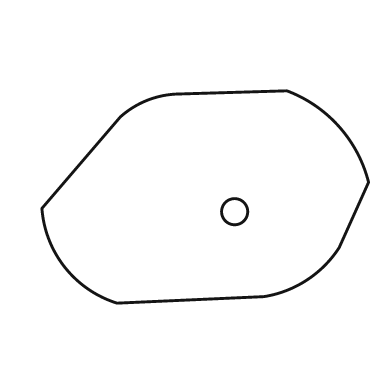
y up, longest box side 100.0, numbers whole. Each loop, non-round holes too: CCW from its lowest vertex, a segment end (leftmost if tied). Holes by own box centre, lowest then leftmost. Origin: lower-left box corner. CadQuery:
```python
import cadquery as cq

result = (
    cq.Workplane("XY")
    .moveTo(23.0, 0.0)
    .lineTo(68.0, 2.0)
    .threePointArc((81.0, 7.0), (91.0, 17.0))
    .lineTo(100.0, 37.0)
    .threePointArc((91.0, 54.0), (75.0, 65.0))
    .lineTo(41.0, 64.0)
    .threePointArc((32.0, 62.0), (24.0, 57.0))
    .lineTo(0.0, 29.0)
    .threePointArc((7.0, 11.0), (23.0, 0.0))
    .close()
    .moveTo(59.0, 28.0)
    .circle(4.0)
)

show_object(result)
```